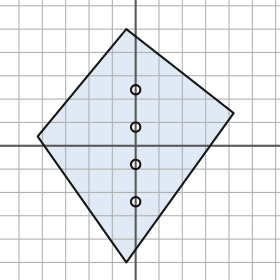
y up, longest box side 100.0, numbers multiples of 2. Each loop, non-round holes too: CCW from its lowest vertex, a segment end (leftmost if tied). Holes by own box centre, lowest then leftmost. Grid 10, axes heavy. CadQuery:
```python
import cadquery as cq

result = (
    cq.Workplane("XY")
    .moveTo(-4.0, -50.0)
    .lineTo(42.0, 14.0)
    .lineTo(-4.0, 50.0)
    .lineTo(-42.0, 4.0)
    .close()
    .moveTo(0.0, -24.0)
    .circle(2.0)
    .moveTo(0.0, -8.0)
    .circle(2.0)
    .moveTo(0.0, 8.0)
    .circle(2.0)
    .moveTo(0.0, 24.0)
    .circle(2.0)
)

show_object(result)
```